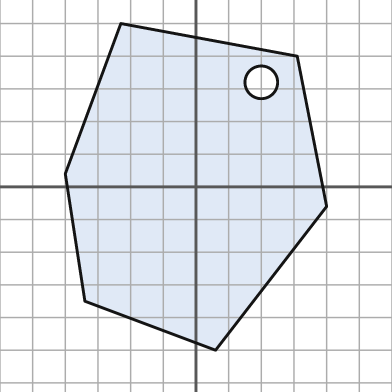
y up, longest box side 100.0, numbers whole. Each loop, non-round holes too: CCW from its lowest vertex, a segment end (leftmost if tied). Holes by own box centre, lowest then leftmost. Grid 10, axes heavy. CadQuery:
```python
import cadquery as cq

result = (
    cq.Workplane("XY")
    .moveTo(6.0, -50.0)
    .lineTo(40.0, -6.0)
    .lineTo(31.0, 40.0)
    .lineTo(-23.0, 50.0)
    .lineTo(-40.0, 4.0)
    .lineTo(-34.0, -35.0)
    .close()
    .moveTo(20.0, 32.0)
    .circle(5.0)
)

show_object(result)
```